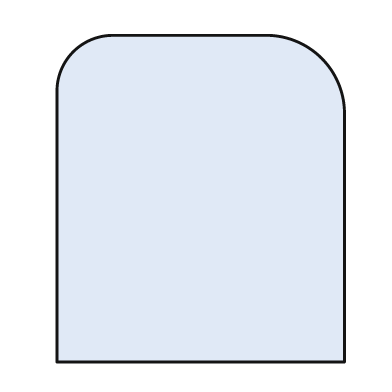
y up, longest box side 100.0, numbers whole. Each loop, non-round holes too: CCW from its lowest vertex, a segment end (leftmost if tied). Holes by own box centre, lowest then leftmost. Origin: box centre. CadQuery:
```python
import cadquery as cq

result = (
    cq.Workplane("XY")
    .moveTo(-44.0, -50.0)
    .lineTo(44.0, -50.0)
    .lineTo(44.0, 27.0)
    .threePointArc((37.0, 43.0), (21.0, 50.0))
    .lineTo(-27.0, 50.0)
    .threePointArc((-39.0, 45.0), (-44.0, 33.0))
    .close()
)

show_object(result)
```